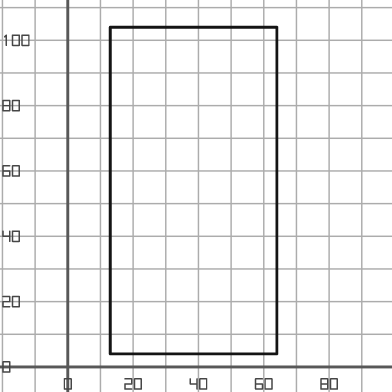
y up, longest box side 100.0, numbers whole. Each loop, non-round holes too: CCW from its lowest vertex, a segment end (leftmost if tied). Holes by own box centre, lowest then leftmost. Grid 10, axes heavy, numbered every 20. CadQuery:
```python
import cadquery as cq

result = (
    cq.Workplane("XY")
    .moveTo(13.0, 4.0)
    .lineTo(64.0, 4.0)
    .lineTo(64.0, 104.0)
    .lineTo(13.0, 104.0)
    .close()
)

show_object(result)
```